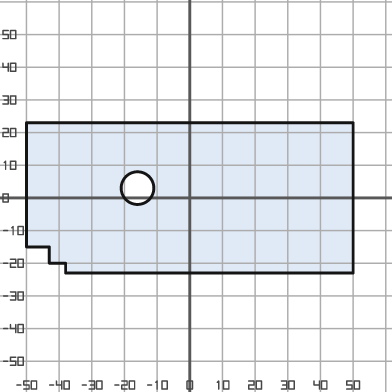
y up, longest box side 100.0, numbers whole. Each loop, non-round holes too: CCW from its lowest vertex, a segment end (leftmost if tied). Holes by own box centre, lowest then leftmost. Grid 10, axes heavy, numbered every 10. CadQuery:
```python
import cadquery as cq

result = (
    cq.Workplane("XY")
    .moveTo(-38.0, -23.0)
    .lineTo(50.0, -23.0)
    .lineTo(50.0, 23.0)
    .lineTo(-50.0, 23.0)
    .lineTo(-50.0, -15.0)
    .lineTo(-43.0, -15.0)
    .lineTo(-43.0, -20.0)
    .lineTo(-38.0, -20.0)
    .close()
    .moveTo(-16.0, 3.0)
    .circle(5.0)
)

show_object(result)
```